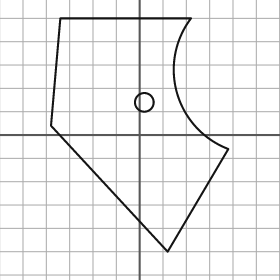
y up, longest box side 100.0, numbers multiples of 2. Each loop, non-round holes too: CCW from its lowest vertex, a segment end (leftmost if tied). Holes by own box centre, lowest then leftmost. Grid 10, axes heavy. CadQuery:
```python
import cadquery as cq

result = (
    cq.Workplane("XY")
    .moveTo(12.0, -50.0)
    .lineTo(38.0, -6.0)
    .threePointArc((16.0, 18.0), (22.0, 50.0))
    .lineTo(-34.0, 50.0)
    .lineTo(-38.0, 4.0)
    .close()
    .moveTo(2.0, 14.0)
    .circle(4.0)
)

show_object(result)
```